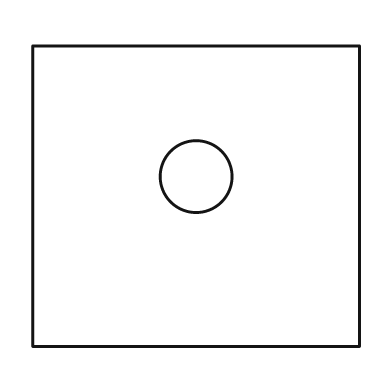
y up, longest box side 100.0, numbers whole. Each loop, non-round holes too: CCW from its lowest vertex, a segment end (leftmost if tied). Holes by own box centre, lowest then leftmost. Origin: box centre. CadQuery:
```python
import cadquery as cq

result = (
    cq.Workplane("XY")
    .moveTo(-50.0, -46.0)
    .lineTo(50.0, -46.0)
    .lineTo(50.0, 46.0)
    .lineTo(-50.0, 46.0)
    .close()
    .moveTo(0.0, 6.0)
    .circle(11.0)
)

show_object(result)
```